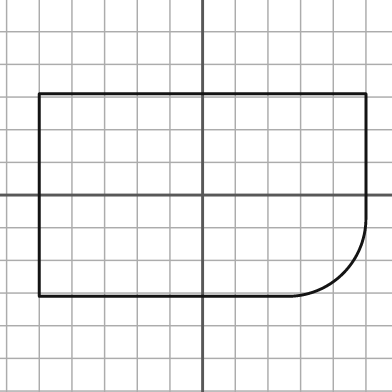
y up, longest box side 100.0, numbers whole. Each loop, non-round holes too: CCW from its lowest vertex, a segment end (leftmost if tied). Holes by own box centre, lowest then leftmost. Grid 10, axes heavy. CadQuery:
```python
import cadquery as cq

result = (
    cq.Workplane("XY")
    .moveTo(-50.0, -31.0)
    .lineTo(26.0, -31.0)
    .threePointArc((43.0, -24.0), (50.0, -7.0))
    .lineTo(50.0, 31.0)
    .lineTo(-50.0, 31.0)
    .close()
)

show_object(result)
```